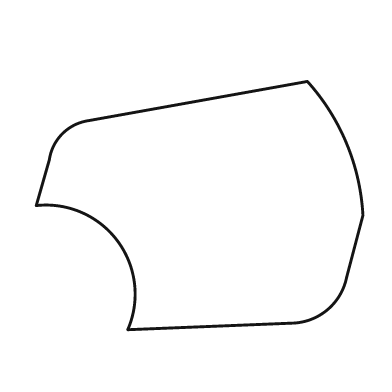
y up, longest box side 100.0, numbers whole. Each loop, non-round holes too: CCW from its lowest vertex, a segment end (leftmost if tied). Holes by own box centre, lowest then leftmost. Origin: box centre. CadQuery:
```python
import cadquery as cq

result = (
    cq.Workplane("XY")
    .moveTo(-22.0, -38.0)
    .lineTo(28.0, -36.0)
    .threePointArc((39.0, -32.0), (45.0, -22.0))
    .lineTo(50.0, -3.0)
    .threePointArc((45.0, 19.0), (33.0, 38.0))
    .lineTo(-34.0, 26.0)
    .threePointArc((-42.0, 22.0), (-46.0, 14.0))
    .lineTo(-50.0, 0.0)
    .threePointArc((-25.0, -11.0), (-22.0, -38.0))
    .close()
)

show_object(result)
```